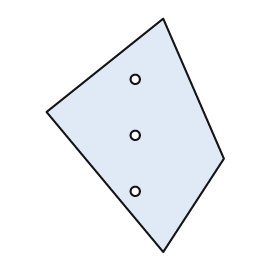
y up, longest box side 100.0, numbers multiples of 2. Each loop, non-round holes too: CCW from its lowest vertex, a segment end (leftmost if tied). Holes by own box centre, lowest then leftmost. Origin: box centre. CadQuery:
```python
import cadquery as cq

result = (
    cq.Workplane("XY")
    .moveTo(12.0, -50.0)
    .lineTo(38.0, -10.0)
    .lineTo(12.0, 50.0)
    .lineTo(-38.0, 10.0)
    .close()
    .moveTo(0.0, -24.0)
    .circle(2.0)
    .moveTo(0.0, 0.0)
    .circle(2.0)
    .moveTo(0.0, 24.0)
    .circle(2.0)
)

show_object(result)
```